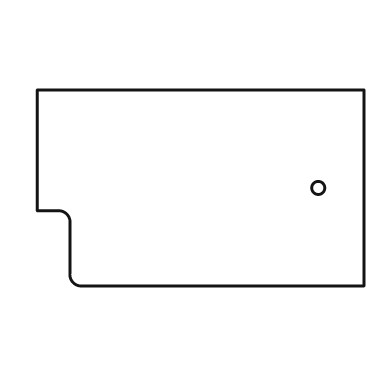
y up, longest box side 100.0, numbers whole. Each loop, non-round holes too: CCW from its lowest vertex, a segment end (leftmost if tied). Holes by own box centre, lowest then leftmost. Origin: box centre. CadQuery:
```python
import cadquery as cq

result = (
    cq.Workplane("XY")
    .moveTo(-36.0, -30.0)
    .lineTo(50.0, -30.0)
    .lineTo(50.0, 30.0)
    .lineTo(-50.0, 30.0)
    .lineTo(-50.0, -7.0)
    .lineTo(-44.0, -7.0)
    .threePointArc((-41.0, -8.0), (-40.0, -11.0))
    .lineTo(-40.0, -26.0)
    .threePointArc((-39.0, -29.0), (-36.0, -30.0))
    .close()
    .moveTo(36.0, 0.0)
    .circle(2.0)
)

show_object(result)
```